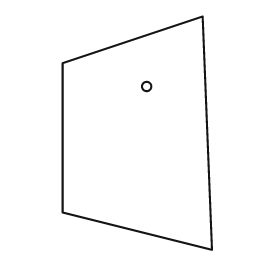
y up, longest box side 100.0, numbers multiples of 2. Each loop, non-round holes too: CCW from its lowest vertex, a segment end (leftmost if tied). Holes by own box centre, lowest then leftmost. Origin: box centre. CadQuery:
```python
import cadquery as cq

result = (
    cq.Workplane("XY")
    .moveTo(32.0, -50.0)
    .lineTo(28.0, 50.0)
    .lineTo(-32.0, 30.0)
    .lineTo(-32.0, -34.0)
    .close()
    .moveTo(4.0, 20.0)
    .circle(2.0)
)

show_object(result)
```